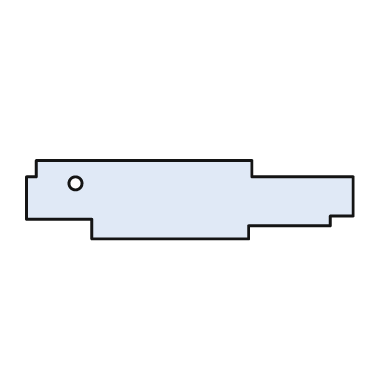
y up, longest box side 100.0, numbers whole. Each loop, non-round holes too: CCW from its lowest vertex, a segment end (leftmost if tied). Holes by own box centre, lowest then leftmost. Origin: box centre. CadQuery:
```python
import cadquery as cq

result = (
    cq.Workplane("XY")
    .moveTo(-30.0, -12.0)
    .lineTo(18.0, -12.0)
    .lineTo(18.0, -8.0)
    .lineTo(43.0, -8.0)
    .lineTo(43.0, -5.0)
    .lineTo(50.0, -5.0)
    .lineTo(50.0, 7.0)
    .lineTo(19.0, 7.0)
    .lineTo(19.0, 12.0)
    .lineTo(-47.0, 12.0)
    .lineTo(-47.0, 7.0)
    .lineTo(-50.0, 7.0)
    .lineTo(-50.0, -6.0)
    .lineTo(-30.0, -6.0)
    .close()
    .moveTo(-35.0, 5.0)
    .circle(2.0)
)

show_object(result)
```